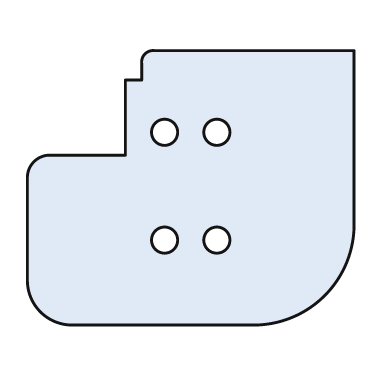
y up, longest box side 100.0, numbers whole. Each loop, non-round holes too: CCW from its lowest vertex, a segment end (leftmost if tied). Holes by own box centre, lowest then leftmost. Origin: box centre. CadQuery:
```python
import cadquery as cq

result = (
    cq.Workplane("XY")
    .moveTo(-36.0, -42.0)
    .lineTo(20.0, -42.0)
    .threePointArc((41.0, -33.0), (50.0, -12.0))
    .lineTo(50.0, 42.0)
    .lineTo(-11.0, 42.0)
    .threePointArc((-14.0, 41.0), (-15.0, 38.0))
    .lineTo(-15.0, 33.0)
    .lineTo(-20.0, 33.0)
    .lineTo(-20.0, 10.0)
    .lineTo(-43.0, 10.0)
    .threePointArc((-48.0, 8.0), (-50.0, 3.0))
    .lineTo(-50.0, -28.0)
    .threePointArc((-46.0, -38.0), (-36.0, -42.0))
    .close()
    .moveTo(-8.0, -16.0)
    .circle(4.0)
    .moveTo(8.0, -16.0)
    .circle(4.0)
    .moveTo(-8.0, 17.0)
    .circle(4.0)
    .moveTo(8.0, 17.0)
    .circle(4.0)
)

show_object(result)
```